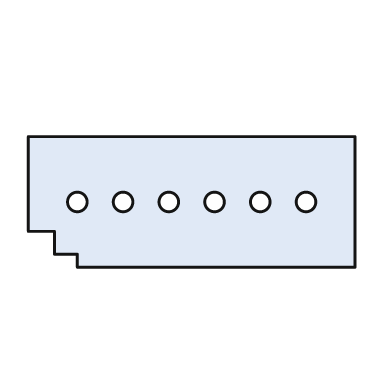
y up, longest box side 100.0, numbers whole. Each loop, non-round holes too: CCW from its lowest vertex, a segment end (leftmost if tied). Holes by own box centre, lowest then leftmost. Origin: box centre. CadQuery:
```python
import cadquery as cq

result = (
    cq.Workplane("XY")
    .moveTo(-35.0, -20.0)
    .lineTo(50.0, -20.0)
    .lineTo(50.0, 20.0)
    .lineTo(-50.0, 20.0)
    .lineTo(-50.0, -9.0)
    .lineTo(-42.0, -9.0)
    .lineTo(-42.0, -16.0)
    .lineTo(-35.0, -16.0)
    .close()
    .moveTo(-35.0, 0.0)
    .circle(3.0)
    .moveTo(-21.0, 0.0)
    .circle(3.0)
    .moveTo(-7.0, 0.0)
    .circle(3.0)
    .moveTo(7.0, 0.0)
    .circle(3.0)
    .moveTo(21.0, 0.0)
    .circle(3.0)
    .moveTo(35.0, 0.0)
    .circle(3.0)
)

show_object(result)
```